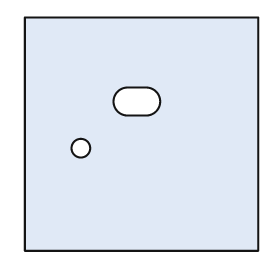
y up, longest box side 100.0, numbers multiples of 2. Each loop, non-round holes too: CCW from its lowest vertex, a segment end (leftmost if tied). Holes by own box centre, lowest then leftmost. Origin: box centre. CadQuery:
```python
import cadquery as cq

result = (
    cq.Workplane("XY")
    .moveTo(-50.0, -50.0)
    .lineTo(50.0, -50.0)
    .lineTo(50.0, 50.0)
    .lineTo(-50.0, 50.0)
    .close()
    .moveTo(-26.0, -6.0)
    .circle(4.0)
    .moveTo(-6.0, 8.0)
    .lineTo(2.0, 8.0)
    .threePointArc((8.0, 14.0), (2.0, 20.0))
    .lineTo(-6.0, 20.0)
    .threePointArc((-12.0, 14.0), (-6.0, 8.0))
    .close()
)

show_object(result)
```